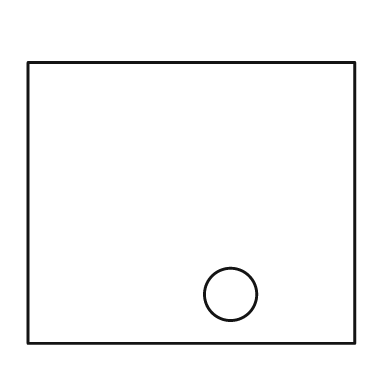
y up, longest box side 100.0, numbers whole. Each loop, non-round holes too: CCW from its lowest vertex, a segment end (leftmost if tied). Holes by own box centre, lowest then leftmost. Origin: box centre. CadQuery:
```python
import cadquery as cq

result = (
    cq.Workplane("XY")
    .moveTo(-50.0, -43.0)
    .lineTo(50.0, -43.0)
    .lineTo(50.0, 43.0)
    .lineTo(-50.0, 43.0)
    .close()
    .moveTo(12.0, -28.0)
    .circle(8.0)
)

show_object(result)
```